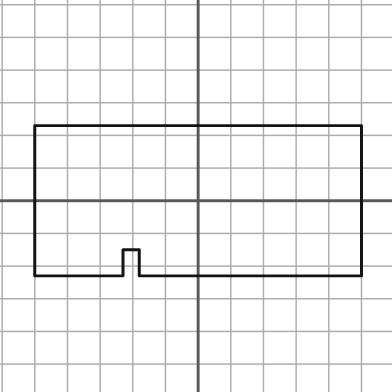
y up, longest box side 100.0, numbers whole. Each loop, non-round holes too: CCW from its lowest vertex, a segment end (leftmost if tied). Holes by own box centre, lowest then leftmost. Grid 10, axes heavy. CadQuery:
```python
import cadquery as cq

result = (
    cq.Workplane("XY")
    .moveTo(-50.0, -23.0)
    .lineTo(-23.0, -23.0)
    .lineTo(-23.0, -15.0)
    .lineTo(-18.0, -15.0)
    .lineTo(-18.0, -23.0)
    .lineTo(50.0, -23.0)
    .lineTo(50.0, 23.0)
    .lineTo(-50.0, 23.0)
    .close()
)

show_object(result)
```